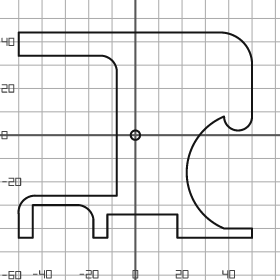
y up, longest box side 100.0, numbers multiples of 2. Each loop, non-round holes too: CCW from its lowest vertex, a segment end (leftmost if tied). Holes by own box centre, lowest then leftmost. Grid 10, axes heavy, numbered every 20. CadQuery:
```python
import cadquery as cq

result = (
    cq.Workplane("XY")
    .moveTo(-50.0, -44.0)
    .lineTo(-44.0, -44.0)
    .lineTo(-44.0, -30.0)
    .lineTo(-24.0, -30.0)
    .threePointArc((-20.0, -32.0), (-18.0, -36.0))
    .lineTo(-18.0, -44.0)
    .lineTo(-12.0, -44.0)
    .lineTo(-12.0, -34.0)
    .lineTo(18.0, -34.0)
    .lineTo(18.0, -44.0)
    .lineTo(50.0, -44.0)
    .lineTo(50.0, -40.0)
    .lineTo(38.0, -40.0)
    .threePointArc((22.0, -16.0), (38.0, 8.0))
    .threePointArc((44.0, 2.0), (50.0, 8.0))
    .lineTo(50.0, 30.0)
    .threePointArc((46.0, 40.0), (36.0, 44.0))
    .lineTo(-50.0, 44.0)
    .lineTo(-50.0, 34.0)
    .lineTo(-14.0, 34.0)
    .threePointArc((-10.0, 32.0), (-8.0, 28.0))
    .lineTo(-8.0, -26.0)
    .lineTo(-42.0, -26.0)
    .threePointArc((-48.0, -28.0), (-50.0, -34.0))
    .close()
    .moveTo(0.0, 0.0)
    .circle(2.0)
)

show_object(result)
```